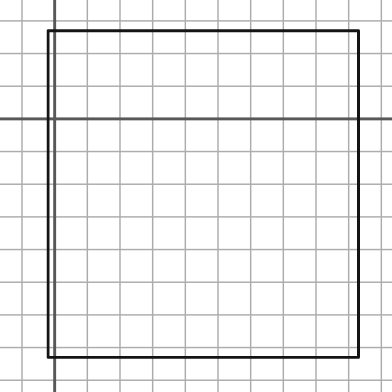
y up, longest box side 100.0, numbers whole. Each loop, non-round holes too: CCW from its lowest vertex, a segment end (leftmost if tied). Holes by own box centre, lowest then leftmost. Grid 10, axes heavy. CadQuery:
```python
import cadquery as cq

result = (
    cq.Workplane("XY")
    .moveTo(-2.0, -73.0)
    .lineTo(93.0, -73.0)
    .lineTo(93.0, 27.0)
    .lineTo(-2.0, 27.0)
    .close()
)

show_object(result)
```